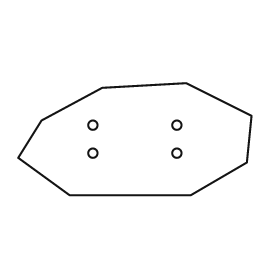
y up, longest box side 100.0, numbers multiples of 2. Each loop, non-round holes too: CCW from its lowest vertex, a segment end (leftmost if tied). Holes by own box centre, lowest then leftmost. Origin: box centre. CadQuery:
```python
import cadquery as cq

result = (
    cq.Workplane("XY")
    .moveTo(-28.0, -24.0)
    .lineTo(24.0, -24.0)
    .lineTo(48.0, -10.0)
    .lineTo(50.0, 10.0)
    .lineTo(22.0, 24.0)
    .lineTo(-14.0, 22.0)
    .lineTo(-40.0, 8.0)
    .lineTo(-50.0, -8.0)
    .close()
    .moveTo(-18.0, -6.0)
    .circle(2.0)
    .moveTo(18.0, -6.0)
    .circle(2.0)
    .moveTo(-18.0, 6.0)
    .circle(2.0)
    .moveTo(18.0, 6.0)
    .circle(2.0)
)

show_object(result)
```